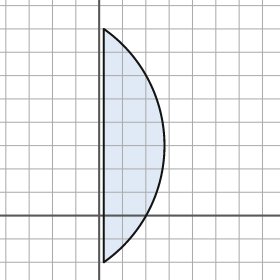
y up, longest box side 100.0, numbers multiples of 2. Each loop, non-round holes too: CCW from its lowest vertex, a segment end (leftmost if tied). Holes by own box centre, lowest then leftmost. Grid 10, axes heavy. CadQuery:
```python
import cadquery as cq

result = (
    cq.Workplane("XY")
    .moveTo(2.0, -20.0)
    .threePointArc((28.0, 30.0), (2.0, 80.0))
    .close()
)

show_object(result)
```